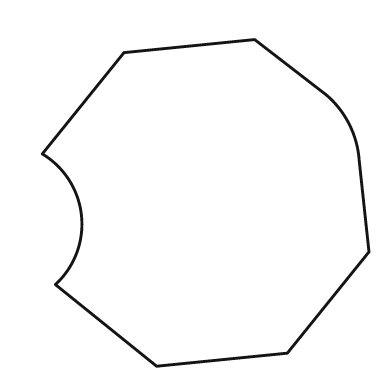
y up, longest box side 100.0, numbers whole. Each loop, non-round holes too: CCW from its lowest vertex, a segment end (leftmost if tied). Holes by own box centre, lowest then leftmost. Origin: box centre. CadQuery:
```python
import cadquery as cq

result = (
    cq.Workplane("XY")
    .moveTo(-15.0, -50.0)
    .lineTo(25.0, -46.0)
    .lineTo(50.0, -15.0)
    .lineTo(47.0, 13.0)
    .threePointArc((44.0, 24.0), (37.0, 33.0))
    .lineTo(15.0, 50.0)
    .lineTo(-25.0, 46.0)
    .lineTo(-50.0, 15.0)
    .threePointArc((-38.0, -4.0), (-46.0, -25.0))
    .close()
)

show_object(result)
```